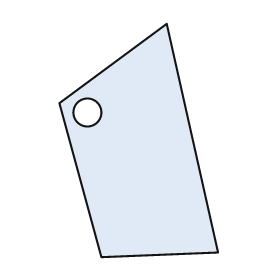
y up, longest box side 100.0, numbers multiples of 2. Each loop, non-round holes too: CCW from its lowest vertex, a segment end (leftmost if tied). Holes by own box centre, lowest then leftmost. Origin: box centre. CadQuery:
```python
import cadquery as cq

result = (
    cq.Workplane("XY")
    .moveTo(-16.0, -50.0)
    .lineTo(34.0, -48.0)
    .lineTo(12.0, 50.0)
    .lineTo(-34.0, 16.0)
    .close()
    .moveTo(-22.0, 12.0)
    .circle(6.0)
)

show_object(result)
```